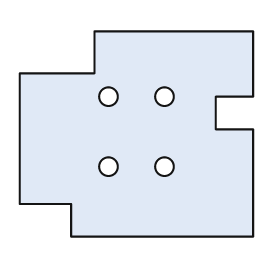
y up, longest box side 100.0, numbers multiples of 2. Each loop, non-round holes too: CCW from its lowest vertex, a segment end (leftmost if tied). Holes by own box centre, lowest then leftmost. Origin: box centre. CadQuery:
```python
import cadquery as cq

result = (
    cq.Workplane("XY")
    .moveTo(-28.0, -44.0)
    .lineTo(50.0, -44.0)
    .lineTo(50.0, 2.0)
    .lineTo(34.0, 2.0)
    .lineTo(34.0, 16.0)
    .lineTo(50.0, 16.0)
    .lineTo(50.0, 44.0)
    .lineTo(-18.0, 44.0)
    .lineTo(-18.0, 26.0)
    .lineTo(-50.0, 26.0)
    .lineTo(-50.0, -30.0)
    .lineTo(-28.0, -30.0)
    .close()
    .moveTo(-12.0, -14.0)
    .circle(4.0)
    .moveTo(12.0, -14.0)
    .circle(4.0)
    .moveTo(-12.0, 16.0)
    .circle(4.0)
    .moveTo(12.0, 16.0)
    .circle(4.0)
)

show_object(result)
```